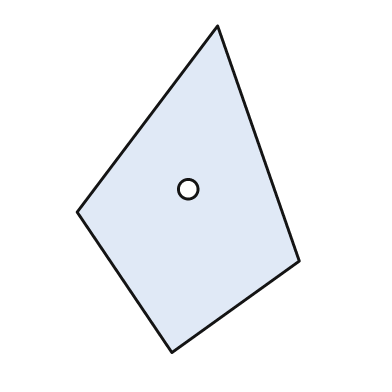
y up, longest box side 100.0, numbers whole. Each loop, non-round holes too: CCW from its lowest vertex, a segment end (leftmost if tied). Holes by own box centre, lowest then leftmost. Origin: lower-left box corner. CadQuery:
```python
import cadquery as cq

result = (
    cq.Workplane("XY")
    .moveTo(29.0, 0.0)
    .lineTo(68.0, 28.0)
    .lineTo(43.0, 100.0)
    .lineTo(0.0, 43.0)
    .close()
    .moveTo(34.0, 50.0)
    .circle(3.0)
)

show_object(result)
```